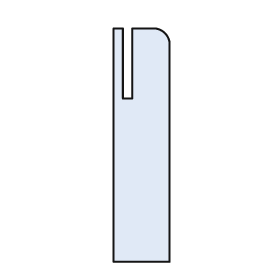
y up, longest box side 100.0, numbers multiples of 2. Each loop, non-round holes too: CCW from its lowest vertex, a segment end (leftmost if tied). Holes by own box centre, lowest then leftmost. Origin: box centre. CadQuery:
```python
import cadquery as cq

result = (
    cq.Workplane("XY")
    .moveTo(-12.0, -50.0)
    .lineTo(12.0, -50.0)
    .lineTo(12.0, 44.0)
    .threePointArc((10.0, 48.0), (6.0, 50.0))
    .lineTo(-4.0, 50.0)
    .lineTo(-4.0, 20.0)
    .lineTo(-8.0, 20.0)
    .lineTo(-8.0, 50.0)
    .lineTo(-12.0, 50.0)
    .close()
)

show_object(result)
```